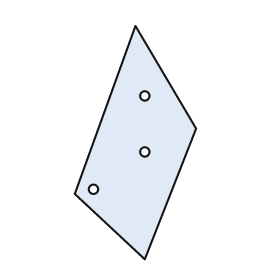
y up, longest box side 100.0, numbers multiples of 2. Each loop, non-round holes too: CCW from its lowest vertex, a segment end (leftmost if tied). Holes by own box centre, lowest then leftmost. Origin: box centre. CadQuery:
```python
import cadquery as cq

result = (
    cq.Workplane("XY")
    .moveTo(4.0, -50.0)
    .lineTo(26.0, 6.0)
    .lineTo(0.0, 50.0)
    .lineTo(-26.0, -22.0)
    .close()
    .moveTo(-18.0, -20.0)
    .circle(2.0)
    .moveTo(4.0, -4.0)
    .circle(2.0)
    .moveTo(4.0, 20.0)
    .circle(2.0)
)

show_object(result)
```